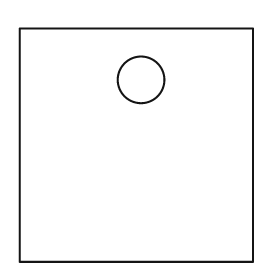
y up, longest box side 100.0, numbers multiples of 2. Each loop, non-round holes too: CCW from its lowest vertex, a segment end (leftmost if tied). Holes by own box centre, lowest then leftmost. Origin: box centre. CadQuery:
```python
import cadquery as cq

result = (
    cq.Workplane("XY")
    .moveTo(-50.0, -50.0)
    .lineTo(50.0, -50.0)
    .lineTo(50.0, 50.0)
    .lineTo(-50.0, 50.0)
    .close()
    .moveTo(2.0, 28.0)
    .circle(10.0)
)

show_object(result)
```